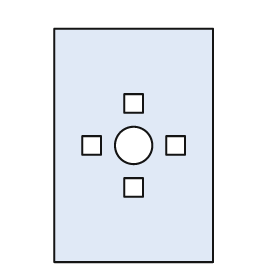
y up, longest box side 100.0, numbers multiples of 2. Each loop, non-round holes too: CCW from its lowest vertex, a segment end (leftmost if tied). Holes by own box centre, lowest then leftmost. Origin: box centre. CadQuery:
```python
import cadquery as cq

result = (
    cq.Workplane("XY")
    .moveTo(-34.0, -50.0)
    .lineTo(34.0, -50.0)
    .lineTo(34.0, 50.0)
    .lineTo(-34.0, 50.0)
    .close()
    .moveTo(-4.0, -22.0)
    .lineTo(4.0, -22.0)
    .lineTo(4.0, -14.0)
    .lineTo(-4.0, -14.0)
    .close()
    .moveTo(-22.0, -4.0)
    .lineTo(-14.0, -4.0)
    .lineTo(-14.0, 4.0)
    .lineTo(-22.0, 4.0)
    .close()
    .moveTo(0.0, 0.0)
    .circle(8.0)
    .moveTo(14.0, -4.0)
    .lineTo(22.0, -4.0)
    .lineTo(22.0, 4.0)
    .lineTo(14.0, 4.0)
    .close()
    .moveTo(-4.0, 14.0)
    .lineTo(4.0, 14.0)
    .lineTo(4.0, 22.0)
    .lineTo(-4.0, 22.0)
    .close()
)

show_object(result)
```